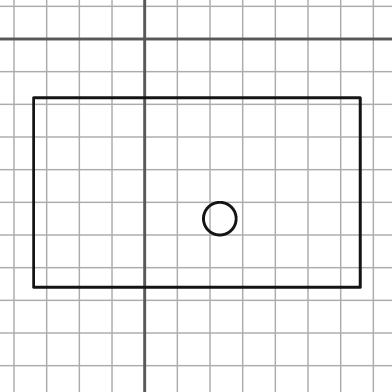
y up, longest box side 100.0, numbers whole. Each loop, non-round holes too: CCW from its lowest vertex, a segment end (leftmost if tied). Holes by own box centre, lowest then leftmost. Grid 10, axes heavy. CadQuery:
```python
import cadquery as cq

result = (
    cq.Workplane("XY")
    .moveTo(-34.0, -76.0)
    .lineTo(66.0, -76.0)
    .lineTo(66.0, -18.0)
    .lineTo(-34.0, -18.0)
    .close()
    .moveTo(23.0, -55.0)
    .circle(5.0)
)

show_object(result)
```